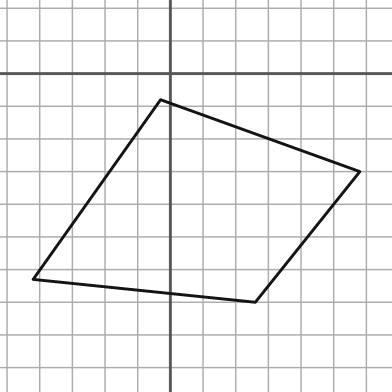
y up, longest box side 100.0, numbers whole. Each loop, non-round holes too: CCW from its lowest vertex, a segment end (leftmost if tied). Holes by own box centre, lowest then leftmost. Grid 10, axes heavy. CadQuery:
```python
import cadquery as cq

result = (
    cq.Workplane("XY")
    .moveTo(26.0, -70.0)
    .lineTo(58.0, -30.0)
    .lineTo(-3.0, -8.0)
    .lineTo(-42.0, -63.0)
    .close()
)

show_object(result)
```